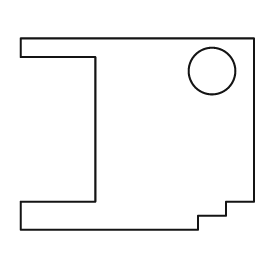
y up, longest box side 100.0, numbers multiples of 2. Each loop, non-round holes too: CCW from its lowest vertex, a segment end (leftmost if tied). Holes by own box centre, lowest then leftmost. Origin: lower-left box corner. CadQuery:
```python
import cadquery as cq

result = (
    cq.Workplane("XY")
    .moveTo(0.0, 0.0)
    .lineTo(76.0, 0.0)
    .lineTo(76.0, 6.0)
    .lineTo(88.0, 6.0)
    .lineTo(88.0, 12.0)
    .lineTo(100.0, 12.0)
    .lineTo(100.0, 82.0)
    .lineTo(0.0, 82.0)
    .lineTo(0.0, 74.0)
    .lineTo(32.0, 74.0)
    .lineTo(32.0, 12.0)
    .lineTo(0.0, 12.0)
    .close()
    .moveTo(82.0, 68.0)
    .circle(10.0)
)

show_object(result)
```